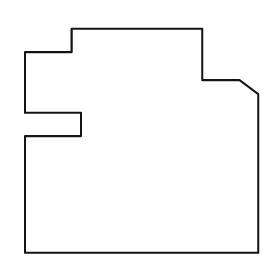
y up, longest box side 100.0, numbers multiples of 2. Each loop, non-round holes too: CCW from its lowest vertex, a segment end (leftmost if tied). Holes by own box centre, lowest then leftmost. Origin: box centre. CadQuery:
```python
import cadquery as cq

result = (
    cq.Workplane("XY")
    .moveTo(-50.0, -48.0)
    .lineTo(50.0, -48.0)
    .lineTo(50.0, 20.0)
    .lineTo(42.0, 26.0)
    .lineTo(26.0, 26.0)
    .lineTo(26.0, 48.0)
    .lineTo(-30.0, 48.0)
    .lineTo(-30.0, 38.0)
    .lineTo(-50.0, 38.0)
    .lineTo(-50.0, 12.0)
    .lineTo(-26.0, 12.0)
    .lineTo(-26.0, 2.0)
    .lineTo(-50.0, 2.0)
    .close()
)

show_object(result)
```